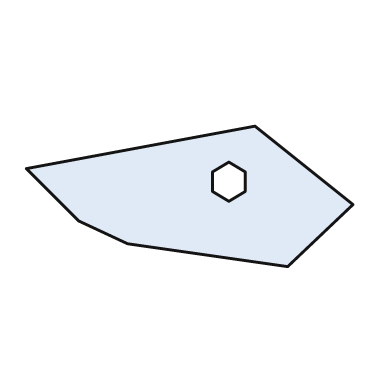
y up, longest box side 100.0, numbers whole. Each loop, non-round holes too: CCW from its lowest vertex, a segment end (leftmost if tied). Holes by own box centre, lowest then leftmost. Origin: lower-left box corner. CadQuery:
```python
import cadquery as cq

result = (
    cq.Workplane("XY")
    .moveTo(80.0, 0.0)
    .lineTo(100.0, 19.0)
    .lineTo(70.0, 43.0)
    .lineTo(0.0, 30.0)
    .lineTo(16.0, 14.0)
    .lineTo(31.0, 7.0)
    .close()
    .moveTo(62.0, 20.0)
    .lineTo(67.0, 23.0)
    .lineTo(67.0, 29.0)
    .lineTo(62.0, 32.0)
    .lineTo(57.0, 29.0)
    .lineTo(57.0, 23.0)
    .close()
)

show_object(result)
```